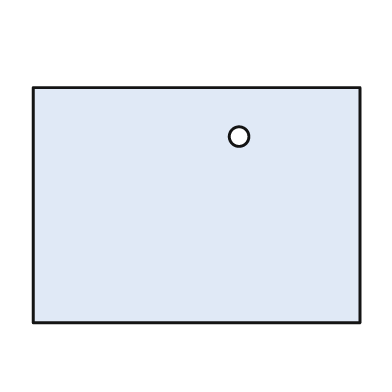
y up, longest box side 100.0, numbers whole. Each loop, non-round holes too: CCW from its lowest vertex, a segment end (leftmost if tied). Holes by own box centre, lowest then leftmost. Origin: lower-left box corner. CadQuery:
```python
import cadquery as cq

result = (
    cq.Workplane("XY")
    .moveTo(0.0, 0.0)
    .lineTo(100.0, 0.0)
    .lineTo(100.0, 72.0)
    .lineTo(0.0, 72.0)
    .close()
    .moveTo(63.0, 57.0)
    .circle(3.0)
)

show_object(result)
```